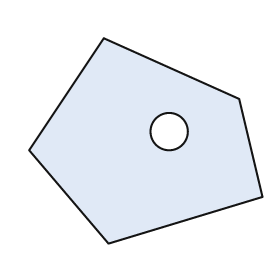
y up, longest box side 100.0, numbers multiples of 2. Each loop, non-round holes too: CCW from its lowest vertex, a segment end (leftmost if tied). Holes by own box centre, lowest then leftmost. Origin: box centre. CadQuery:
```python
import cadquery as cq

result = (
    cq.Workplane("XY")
    .moveTo(-16.0, -44.0)
    .lineTo(50.0, -24.0)
    .lineTo(40.0, 18.0)
    .lineTo(-18.0, 44.0)
    .lineTo(-50.0, -4.0)
    .close()
    .moveTo(10.0, 4.0)
    .circle(8.0)
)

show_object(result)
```